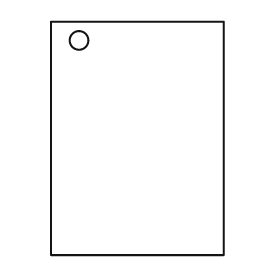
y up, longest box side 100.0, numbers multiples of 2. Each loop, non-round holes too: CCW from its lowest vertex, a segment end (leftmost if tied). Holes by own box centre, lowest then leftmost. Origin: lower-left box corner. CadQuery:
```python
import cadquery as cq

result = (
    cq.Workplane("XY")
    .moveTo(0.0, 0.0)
    .lineTo(74.0, 0.0)
    .lineTo(74.0, 100.0)
    .lineTo(0.0, 100.0)
    .close()
    .moveTo(12.0, 92.0)
    .circle(4.0)
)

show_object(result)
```